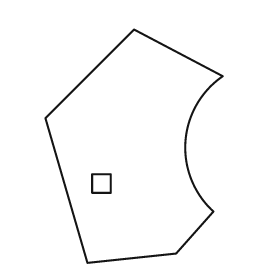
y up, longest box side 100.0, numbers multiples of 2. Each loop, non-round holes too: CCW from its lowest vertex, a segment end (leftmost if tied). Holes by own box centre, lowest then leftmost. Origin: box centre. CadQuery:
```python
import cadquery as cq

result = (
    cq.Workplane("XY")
    .moveTo(-20.0, -50.0)
    .lineTo(18.0, -46.0)
    .lineTo(34.0, -28.0)
    .threePointArc((22.0, 2.0), (38.0, 30.0))
    .lineTo(0.0, 50.0)
    .lineTo(-38.0, 12.0)
    .close()
    .moveTo(-18.0, -20.0)
    .lineTo(-10.0, -20.0)
    .lineTo(-10.0, -12.0)
    .lineTo(-18.0, -12.0)
    .close()
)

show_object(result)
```